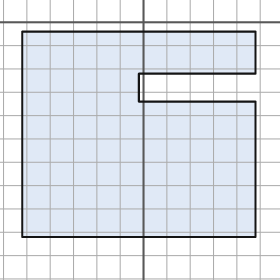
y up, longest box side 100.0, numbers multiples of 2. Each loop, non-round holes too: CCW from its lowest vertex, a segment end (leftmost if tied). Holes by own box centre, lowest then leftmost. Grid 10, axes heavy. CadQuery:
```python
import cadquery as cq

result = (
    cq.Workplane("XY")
    .moveTo(-52.0, -92.0)
    .lineTo(48.0, -92.0)
    .lineTo(48.0, -34.0)
    .lineTo(-2.0, -34.0)
    .lineTo(-2.0, -22.0)
    .lineTo(48.0, -22.0)
    .lineTo(48.0, -4.0)
    .lineTo(-52.0, -4.0)
    .close()
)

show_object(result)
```